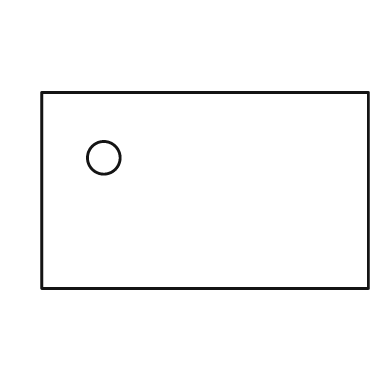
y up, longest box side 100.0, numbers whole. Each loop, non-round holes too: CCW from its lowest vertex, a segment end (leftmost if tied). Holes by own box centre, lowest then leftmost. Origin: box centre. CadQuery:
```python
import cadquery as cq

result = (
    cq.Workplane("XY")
    .moveTo(-50.0, -30.0)
    .lineTo(50.0, -30.0)
    .lineTo(50.0, 30.0)
    .lineTo(-50.0, 30.0)
    .close()
    .moveTo(-31.0, 10.0)
    .circle(5.0)
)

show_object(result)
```